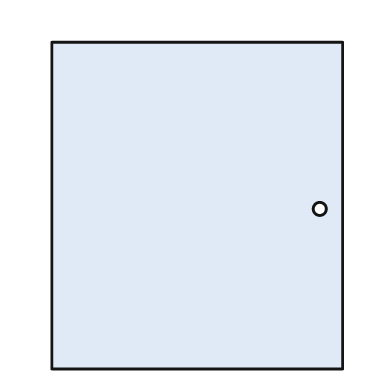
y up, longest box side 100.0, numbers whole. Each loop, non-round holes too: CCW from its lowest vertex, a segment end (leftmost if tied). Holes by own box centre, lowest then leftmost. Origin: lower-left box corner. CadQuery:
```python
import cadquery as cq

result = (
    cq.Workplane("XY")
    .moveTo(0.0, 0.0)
    .lineTo(89.0, 0.0)
    .lineTo(89.0, 100.0)
    .lineTo(0.0, 100.0)
    .close()
    .moveTo(82.0, 49.0)
    .circle(2.0)
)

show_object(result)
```